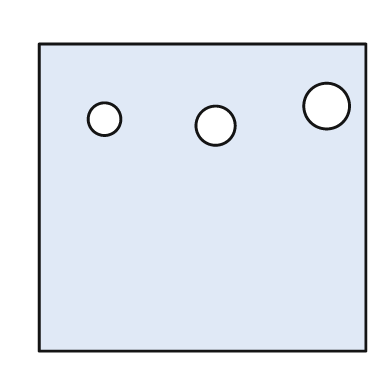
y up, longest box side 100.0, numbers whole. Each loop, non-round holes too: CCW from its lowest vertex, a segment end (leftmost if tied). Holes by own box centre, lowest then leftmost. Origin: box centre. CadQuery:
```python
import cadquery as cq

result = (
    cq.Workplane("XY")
    .moveTo(-50.0, -47.0)
    .lineTo(50.0, -47.0)
    .lineTo(50.0, 47.0)
    .lineTo(-50.0, 47.0)
    .close()
    .moveTo(4.0, 22.0)
    .circle(6.0)
    .moveTo(-30.0, 24.0)
    .circle(5.0)
    .moveTo(38.0, 28.0)
    .circle(7.0)
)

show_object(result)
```